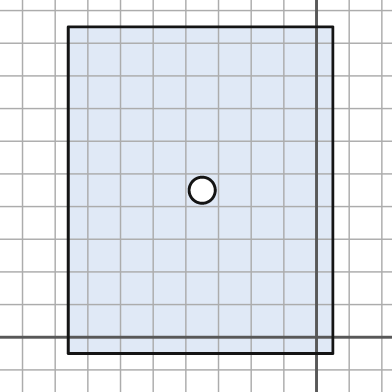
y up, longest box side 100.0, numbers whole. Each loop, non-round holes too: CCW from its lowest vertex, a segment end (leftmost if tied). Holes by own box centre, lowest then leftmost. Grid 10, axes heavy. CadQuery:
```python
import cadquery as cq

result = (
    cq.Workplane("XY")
    .moveTo(-76.0, -5.0)
    .lineTo(5.0, -5.0)
    .lineTo(5.0, 95.0)
    .lineTo(-76.0, 95.0)
    .close()
    .moveTo(-35.0, 45.0)
    .circle(4.0)
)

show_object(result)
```